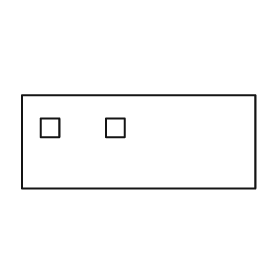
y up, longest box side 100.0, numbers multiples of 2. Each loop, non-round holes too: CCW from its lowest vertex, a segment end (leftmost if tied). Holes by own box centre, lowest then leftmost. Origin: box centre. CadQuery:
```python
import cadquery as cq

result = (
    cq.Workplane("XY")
    .moveTo(-50.0, -20.0)
    .lineTo(50.0, -20.0)
    .lineTo(50.0, 20.0)
    .lineTo(-50.0, 20.0)
    .close()
    .moveTo(-42.0, 2.0)
    .lineTo(-34.0, 2.0)
    .lineTo(-34.0, 10.0)
    .lineTo(-42.0, 10.0)
    .close()
    .moveTo(-14.0, 2.0)
    .lineTo(-6.0, 2.0)
    .lineTo(-6.0, 10.0)
    .lineTo(-14.0, 10.0)
    .close()
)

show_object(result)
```